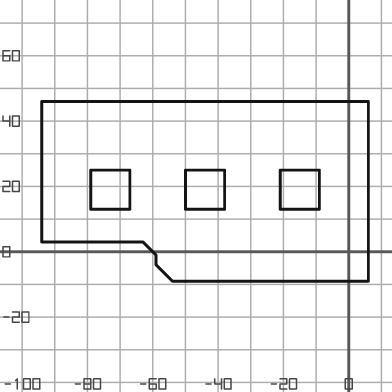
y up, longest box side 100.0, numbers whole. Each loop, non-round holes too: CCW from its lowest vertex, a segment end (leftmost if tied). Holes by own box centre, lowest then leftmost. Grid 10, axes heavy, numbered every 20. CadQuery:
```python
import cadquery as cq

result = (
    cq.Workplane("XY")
    .moveTo(-54.0, -9.0)
    .lineTo(6.0, -9.0)
    .lineTo(6.0, 46.0)
    .lineTo(-94.0, 46.0)
    .lineTo(-94.0, 3.0)
    .lineTo(-63.0, 3.0)
    .lineTo(-59.0, -1.0)
    .lineTo(-59.0, -4.0)
    .close()
    .moveTo(-79.0, 13.0)
    .lineTo(-67.0, 13.0)
    .lineTo(-67.0, 25.0)
    .lineTo(-79.0, 25.0)
    .close()
    .moveTo(-50.0, 13.0)
    .lineTo(-38.0, 13.0)
    .lineTo(-38.0, 25.0)
    .lineTo(-50.0, 25.0)
    .close()
    .moveTo(-21.0, 13.0)
    .lineTo(-9.0, 13.0)
    .lineTo(-9.0, 25.0)
    .lineTo(-21.0, 25.0)
    .close()
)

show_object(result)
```